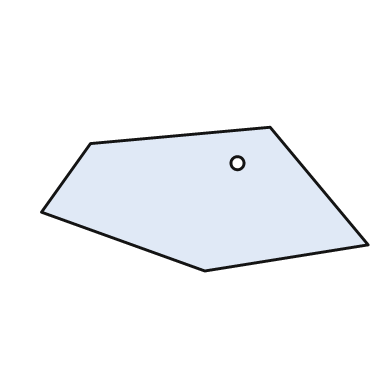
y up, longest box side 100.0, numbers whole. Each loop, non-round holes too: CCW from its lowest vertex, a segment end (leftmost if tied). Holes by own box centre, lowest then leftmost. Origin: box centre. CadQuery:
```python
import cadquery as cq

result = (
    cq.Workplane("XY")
    .moveTo(0.0, -22.0)
    .lineTo(50.0, -14.0)
    .lineTo(20.0, 22.0)
    .lineTo(-35.0, 17.0)
    .lineTo(-50.0, -4.0)
    .close()
    .moveTo(10.0, 11.0)
    .circle(2.0)
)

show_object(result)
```